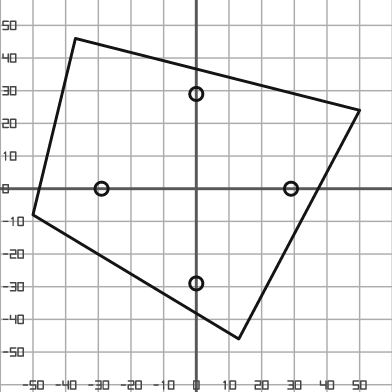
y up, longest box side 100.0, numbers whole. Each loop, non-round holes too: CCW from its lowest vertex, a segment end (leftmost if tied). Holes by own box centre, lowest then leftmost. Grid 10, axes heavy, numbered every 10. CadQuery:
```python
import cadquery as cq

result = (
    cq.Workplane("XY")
    .moveTo(13.0, -46.0)
    .lineTo(50.0, 24.0)
    .lineTo(-37.0, 46.0)
    .lineTo(-50.0, -8.0)
    .close()
    .moveTo(0.0, -29.0)
    .circle(2.0)
    .moveTo(-29.0, 0.0)
    .circle(2.0)
    .moveTo(29.0, 0.0)
    .circle(2.0)
    .moveTo(0.0, 29.0)
    .circle(2.0)
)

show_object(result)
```